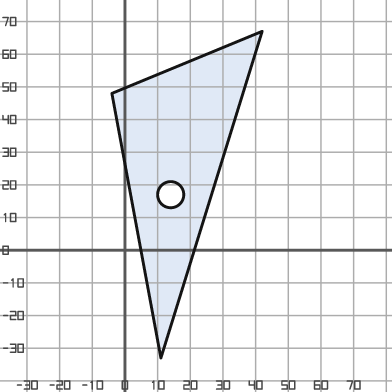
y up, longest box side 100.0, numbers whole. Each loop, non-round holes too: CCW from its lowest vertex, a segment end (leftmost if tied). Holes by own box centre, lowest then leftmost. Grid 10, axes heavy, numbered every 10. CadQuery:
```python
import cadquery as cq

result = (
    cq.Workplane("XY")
    .moveTo(11.0, -33.0)
    .lineTo(42.0, 67.0)
    .lineTo(-4.0, 48.0)
    .close()
    .moveTo(14.0, 17.0)
    .circle(4.0)
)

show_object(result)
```